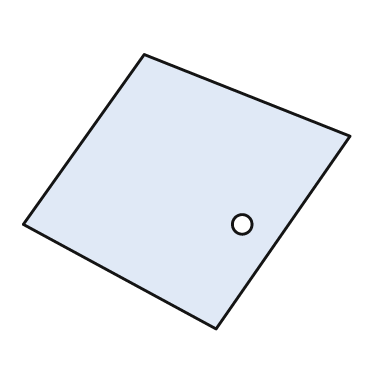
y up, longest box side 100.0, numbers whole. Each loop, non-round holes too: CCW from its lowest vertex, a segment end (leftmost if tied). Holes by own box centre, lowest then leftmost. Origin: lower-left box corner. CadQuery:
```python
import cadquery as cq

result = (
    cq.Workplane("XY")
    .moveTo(59.0, 0.0)
    .lineTo(100.0, 59.0)
    .lineTo(37.0, 84.0)
    .lineTo(0.0, 32.0)
    .close()
    .moveTo(67.0, 32.0)
    .circle(3.0)
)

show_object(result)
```